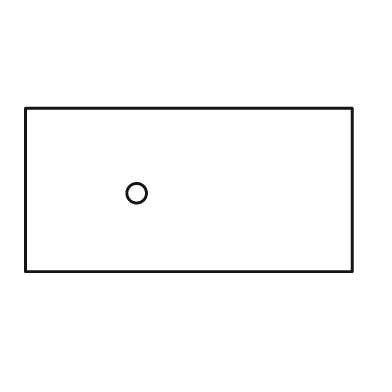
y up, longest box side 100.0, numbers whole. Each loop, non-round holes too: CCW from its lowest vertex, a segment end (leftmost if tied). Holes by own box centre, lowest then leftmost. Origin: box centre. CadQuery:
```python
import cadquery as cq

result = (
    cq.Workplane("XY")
    .moveTo(-50.0, -25.0)
    .lineTo(50.0, -25.0)
    .lineTo(50.0, 25.0)
    .lineTo(-50.0, 25.0)
    .close()
    .moveTo(-16.0, -1.0)
    .circle(3.0)
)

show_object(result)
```